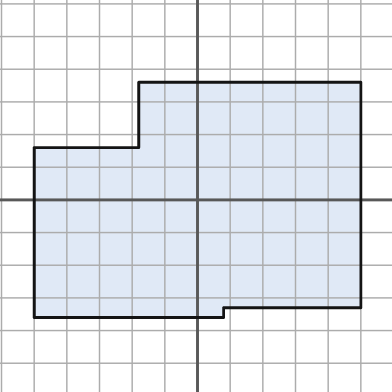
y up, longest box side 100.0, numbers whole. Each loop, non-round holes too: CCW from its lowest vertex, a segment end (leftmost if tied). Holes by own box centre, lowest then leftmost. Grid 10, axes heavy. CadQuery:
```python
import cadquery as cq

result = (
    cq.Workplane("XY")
    .moveTo(-50.0, -36.0)
    .lineTo(8.0, -36.0)
    .lineTo(8.0, -33.0)
    .lineTo(50.0, -33.0)
    .lineTo(50.0, 36.0)
    .lineTo(-18.0, 36.0)
    .lineTo(-18.0, 16.0)
    .lineTo(-50.0, 16.0)
    .close()
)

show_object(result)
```